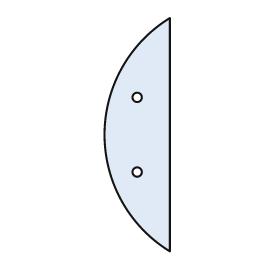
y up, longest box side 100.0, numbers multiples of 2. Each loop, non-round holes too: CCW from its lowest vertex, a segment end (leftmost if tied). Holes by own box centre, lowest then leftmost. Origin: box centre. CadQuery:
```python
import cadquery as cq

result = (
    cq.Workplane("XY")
    .moveTo(14.0, -50.0)
    .lineTo(14.0, 50.0)
    .threePointArc((-14.0, 0.0), (14.0, -50.0))
    .close()
    .moveTo(0.0, -16.0)
    .circle(2.0)
    .moveTo(0.0, 16.0)
    .circle(2.0)
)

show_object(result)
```